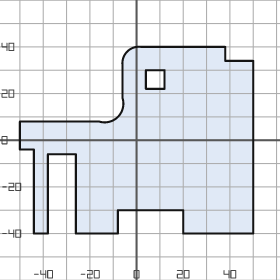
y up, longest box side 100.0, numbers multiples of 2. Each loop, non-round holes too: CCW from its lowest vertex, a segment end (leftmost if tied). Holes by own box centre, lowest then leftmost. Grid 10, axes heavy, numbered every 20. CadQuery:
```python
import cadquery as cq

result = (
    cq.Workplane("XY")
    .moveTo(-44.0, -40.0)
    .lineTo(-38.0, -40.0)
    .lineTo(-38.0, -6.0)
    .lineTo(-26.0, -6.0)
    .lineTo(-26.0, -40.0)
    .lineTo(-8.0, -40.0)
    .lineTo(-8.0, -30.0)
    .lineTo(20.0, -30.0)
    .lineTo(20.0, -40.0)
    .lineTo(50.0, -40.0)
    .lineTo(50.0, 34.0)
    .lineTo(38.0, 34.0)
    .lineTo(38.0, 40.0)
    .lineTo(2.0, 40.0)
    .threePointArc((-4.0, 38.0), (-6.0, 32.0))
    .lineTo(-6.0, 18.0)
    .threePointArc((-8.0, 10.0), (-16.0, 8.0))
    .lineTo(-50.0, 8.0)
    .lineTo(-50.0, -4.0)
    .lineTo(-44.0, -4.0)
    .close()
    .moveTo(4.0, 22.0)
    .lineTo(12.0, 22.0)
    .lineTo(12.0, 30.0)
    .lineTo(4.0, 30.0)
    .close()
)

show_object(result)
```